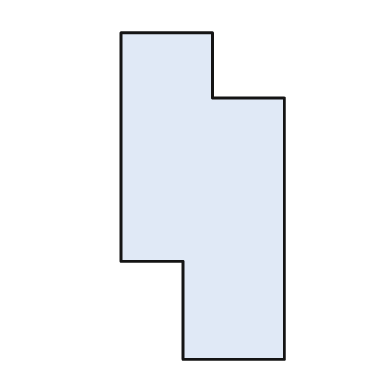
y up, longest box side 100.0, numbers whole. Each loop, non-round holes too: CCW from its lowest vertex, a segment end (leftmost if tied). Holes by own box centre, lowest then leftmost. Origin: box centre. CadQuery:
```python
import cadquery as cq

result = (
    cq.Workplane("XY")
    .moveTo(-6.0, -50.0)
    .lineTo(25.0, -50.0)
    .lineTo(25.0, 30.0)
    .lineTo(3.0, 30.0)
    .lineTo(3.0, 50.0)
    .lineTo(-25.0, 50.0)
    .lineTo(-25.0, -20.0)
    .lineTo(-6.0, -20.0)
    .close()
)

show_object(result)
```